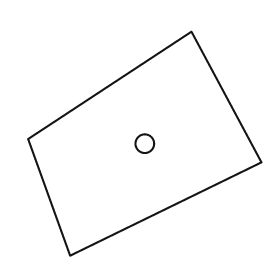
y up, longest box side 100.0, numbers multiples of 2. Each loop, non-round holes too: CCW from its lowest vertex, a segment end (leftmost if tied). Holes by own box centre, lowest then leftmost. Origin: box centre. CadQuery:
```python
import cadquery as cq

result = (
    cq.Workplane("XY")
    .moveTo(-32.0, -48.0)
    .lineTo(50.0, -8.0)
    .lineTo(20.0, 48.0)
    .lineTo(-50.0, 2.0)
    .close()
    .moveTo(0.0, 0.0)
    .circle(4.0)
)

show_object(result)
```